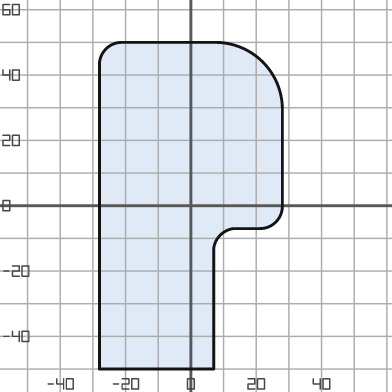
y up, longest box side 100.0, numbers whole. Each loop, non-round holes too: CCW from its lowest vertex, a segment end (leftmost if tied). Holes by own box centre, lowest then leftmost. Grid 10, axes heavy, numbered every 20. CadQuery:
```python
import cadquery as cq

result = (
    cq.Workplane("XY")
    .moveTo(-28.0, -50.0)
    .lineTo(7.0, -50.0)
    .lineTo(7.0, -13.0)
    .threePointArc((9.0, -9.0), (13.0, -7.0))
    .lineTo(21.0, -7.0)
    .threePointArc((26.0, -5.0), (28.0, 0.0))
    .lineTo(28.0, 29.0)
    .threePointArc((22.0, 44.0), (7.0, 50.0))
    .lineTo(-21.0, 50.0)
    .threePointArc((-26.0, 48.0), (-28.0, 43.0))
    .close()
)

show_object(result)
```